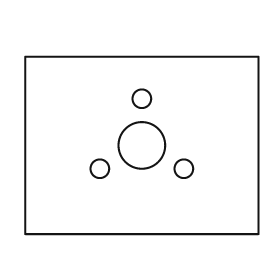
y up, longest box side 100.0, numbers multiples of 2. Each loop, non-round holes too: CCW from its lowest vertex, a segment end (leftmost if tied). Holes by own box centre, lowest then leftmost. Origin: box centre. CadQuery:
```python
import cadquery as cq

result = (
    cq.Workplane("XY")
    .moveTo(-50.0, -38.0)
    .lineTo(50.0, -38.0)
    .lineTo(50.0, 38.0)
    .lineTo(-50.0, 38.0)
    .close()
    .moveTo(-18.0, -10.0)
    .circle(4.0)
    .moveTo(18.0, -10.0)
    .circle(4.0)
    .moveTo(0.0, 0.0)
    .circle(10.0)
    .moveTo(0.0, 20.0)
    .circle(4.0)
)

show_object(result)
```